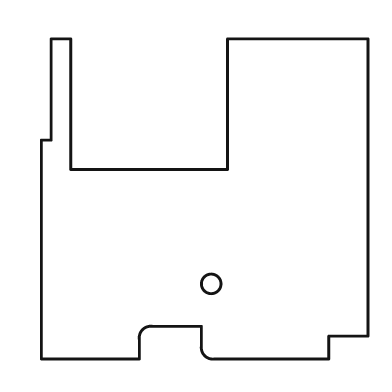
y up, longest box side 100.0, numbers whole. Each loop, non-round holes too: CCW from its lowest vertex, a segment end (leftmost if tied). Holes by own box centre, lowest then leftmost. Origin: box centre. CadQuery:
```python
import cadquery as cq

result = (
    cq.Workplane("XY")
    .moveTo(-50.0, -49.0)
    .lineTo(-20.0, -49.0)
    .lineTo(-20.0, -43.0)
    .threePointArc((-19.0, -40.0), (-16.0, -39.0))
    .lineTo(-1.0, -39.0)
    .lineTo(-1.0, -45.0)
    .threePointArc((0.0, -48.0), (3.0, -49.0))
    .lineTo(38.0, -49.0)
    .lineTo(38.0, -42.0)
    .lineTo(50.0, -42.0)
    .lineTo(50.0, 49.0)
    .lineTo(7.0, 49.0)
    .lineTo(7.0, 9.0)
    .lineTo(-41.0, 9.0)
    .lineTo(-41.0, 49.0)
    .lineTo(-47.0, 49.0)
    .lineTo(-47.0, 18.0)
    .lineTo(-50.0, 18.0)
    .close()
    .moveTo(2.0, -26.0)
    .circle(3.0)
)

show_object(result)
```